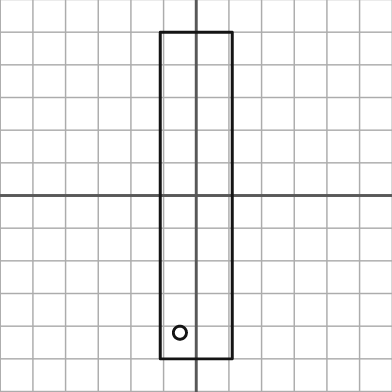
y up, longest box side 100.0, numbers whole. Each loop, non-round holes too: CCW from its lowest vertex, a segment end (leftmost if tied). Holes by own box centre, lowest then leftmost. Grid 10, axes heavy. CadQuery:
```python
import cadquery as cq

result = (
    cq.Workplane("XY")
    .moveTo(-11.0, -50.0)
    .lineTo(11.0, -50.0)
    .lineTo(11.0, 50.0)
    .lineTo(-11.0, 50.0)
    .close()
    .moveTo(-5.0, -42.0)
    .circle(2.0)
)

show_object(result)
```